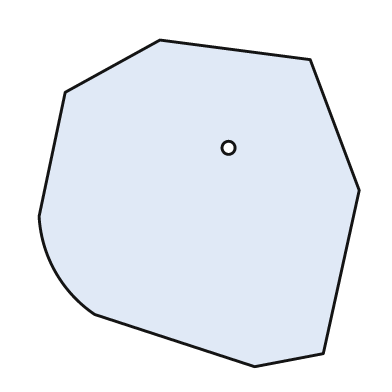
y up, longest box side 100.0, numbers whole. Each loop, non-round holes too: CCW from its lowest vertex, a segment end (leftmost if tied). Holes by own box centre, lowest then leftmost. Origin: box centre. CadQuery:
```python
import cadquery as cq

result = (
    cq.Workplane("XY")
    .moveTo(17.0, -50.0)
    .lineTo(38.0, -46.0)
    .lineTo(49.0, 4.0)
    .lineTo(34.0, 44.0)
    .lineTo(-12.0, 50.0)
    .lineTo(-41.0, 34.0)
    .lineTo(-49.0, -4.0)
    .threePointArc((-44.0, -21.0), (-32.0, -34.0))
    .close()
    .moveTo(9.0, 17.0)
    .circle(2.0)
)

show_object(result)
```